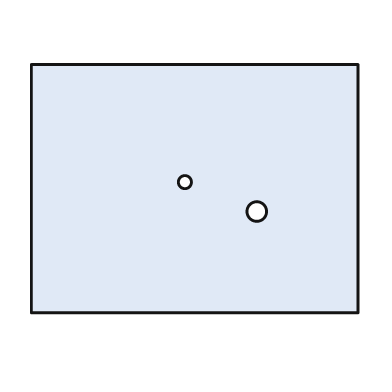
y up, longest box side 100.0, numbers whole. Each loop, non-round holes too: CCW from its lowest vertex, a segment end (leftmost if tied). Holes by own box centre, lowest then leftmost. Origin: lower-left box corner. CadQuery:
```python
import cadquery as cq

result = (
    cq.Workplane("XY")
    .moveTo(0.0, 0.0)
    .lineTo(100.0, 0.0)
    .lineTo(100.0, 76.0)
    .lineTo(0.0, 76.0)
    .close()
    .moveTo(69.0, 31.0)
    .circle(3.0)
    .moveTo(47.0, 40.0)
    .circle(2.0)
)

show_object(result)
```